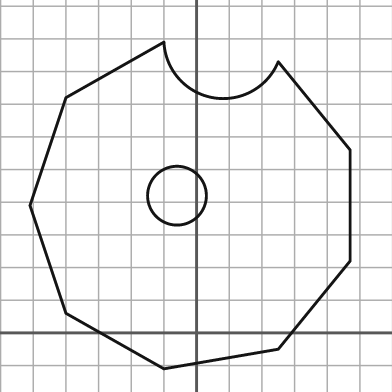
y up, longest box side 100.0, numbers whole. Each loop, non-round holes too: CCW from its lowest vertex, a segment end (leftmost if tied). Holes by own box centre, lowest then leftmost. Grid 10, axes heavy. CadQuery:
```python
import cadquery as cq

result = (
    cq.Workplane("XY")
    .moveTo(-10.0, -11.0)
    .lineTo(25.0, -5.0)
    .lineTo(47.0, 22.0)
    .lineTo(47.0, 56.0)
    .lineTo(25.0, 83.0)
    .threePointArc((5.0, 72.0), (-10.0, 89.0))
    .lineTo(-40.0, 72.0)
    .lineTo(-51.0, 39.0)
    .lineTo(-40.0, 6.0)
    .close()
    .moveTo(-6.0, 42.0)
    .circle(9.0)
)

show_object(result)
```